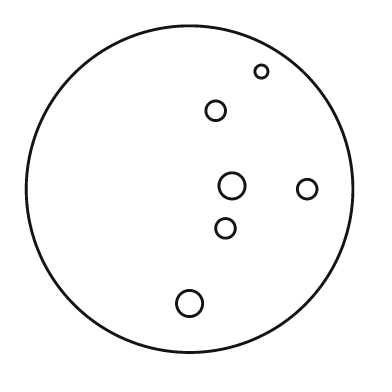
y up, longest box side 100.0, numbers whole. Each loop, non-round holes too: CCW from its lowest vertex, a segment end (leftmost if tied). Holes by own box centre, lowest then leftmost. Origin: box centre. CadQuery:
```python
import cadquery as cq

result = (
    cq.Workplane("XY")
    .moveTo(0.0, 0.0)
    .circle(50.0)
    .moveTo(0.0, -35.0)
    .circle(4.0)
    .moveTo(11.0, -12.0)
    .circle(3.0)
    .moveTo(36.0, 0.0)
    .circle(3.0)
    .moveTo(13.0, 1.0)
    .circle(4.0)
    .moveTo(8.0, 24.0)
    .circle(3.0)
    .moveTo(22.0, 36.0)
    .circle(2.0)
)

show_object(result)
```